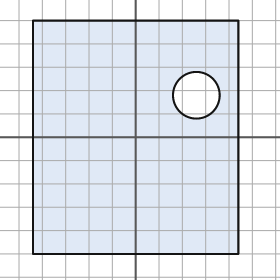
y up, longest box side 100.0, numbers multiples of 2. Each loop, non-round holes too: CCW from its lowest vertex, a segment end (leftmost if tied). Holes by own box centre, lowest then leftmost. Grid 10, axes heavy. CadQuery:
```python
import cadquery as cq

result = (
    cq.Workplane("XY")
    .moveTo(-44.0, -50.0)
    .lineTo(44.0, -50.0)
    .lineTo(44.0, 50.0)
    .lineTo(-44.0, 50.0)
    .close()
    .moveTo(26.0, 18.0)
    .circle(10.0)
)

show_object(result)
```